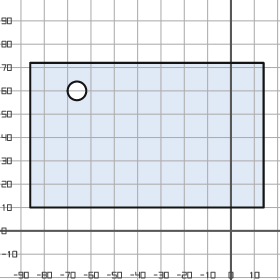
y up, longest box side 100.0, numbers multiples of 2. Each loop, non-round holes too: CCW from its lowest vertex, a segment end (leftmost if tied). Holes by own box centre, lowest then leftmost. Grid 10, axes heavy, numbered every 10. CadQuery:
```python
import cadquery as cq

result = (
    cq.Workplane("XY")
    .moveTo(-86.0, 10.0)
    .lineTo(14.0, 10.0)
    .lineTo(14.0, 72.0)
    .lineTo(-86.0, 72.0)
    .close()
    .moveTo(-66.0, 60.0)
    .circle(4.0)
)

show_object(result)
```